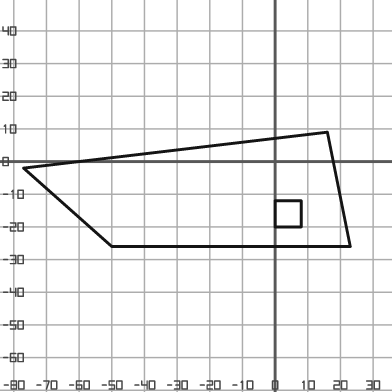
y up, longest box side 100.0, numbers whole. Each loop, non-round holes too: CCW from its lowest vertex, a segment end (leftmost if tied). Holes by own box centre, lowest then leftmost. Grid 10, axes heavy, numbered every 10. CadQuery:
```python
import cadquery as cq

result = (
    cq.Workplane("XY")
    .moveTo(-50.0, -26.0)
    .lineTo(23.0, -26.0)
    .lineTo(16.0, 9.0)
    .lineTo(-77.0, -2.0)
    .close()
    .moveTo(0.0, -20.0)
    .lineTo(8.0, -20.0)
    .lineTo(8.0, -12.0)
    .lineTo(0.0, -12.0)
    .close()
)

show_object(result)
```